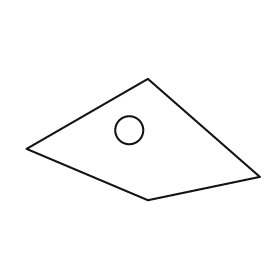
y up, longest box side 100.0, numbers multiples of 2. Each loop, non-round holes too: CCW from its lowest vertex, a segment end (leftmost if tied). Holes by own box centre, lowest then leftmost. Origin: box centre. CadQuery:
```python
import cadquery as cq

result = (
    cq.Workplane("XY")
    .moveTo(2.0, -26.0)
    .lineTo(50.0, -16.0)
    .lineTo(2.0, 26.0)
    .lineTo(-50.0, -4.0)
    .close()
    .moveTo(-6.0, 4.0)
    .circle(6.0)
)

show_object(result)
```